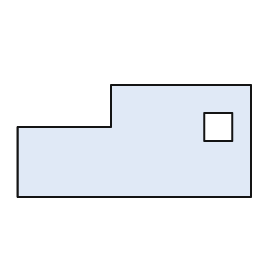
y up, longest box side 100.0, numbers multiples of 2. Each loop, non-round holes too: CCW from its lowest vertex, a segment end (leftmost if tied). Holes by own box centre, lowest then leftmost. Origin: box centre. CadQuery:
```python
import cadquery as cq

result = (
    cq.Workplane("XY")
    .moveTo(-50.0, -24.0)
    .lineTo(50.0, -24.0)
    .lineTo(50.0, 24.0)
    .lineTo(-10.0, 24.0)
    .lineTo(-10.0, 6.0)
    .lineTo(-50.0, 6.0)
    .close()
    .moveTo(30.0, 0.0)
    .lineTo(42.0, 0.0)
    .lineTo(42.0, 12.0)
    .lineTo(30.0, 12.0)
    .close()
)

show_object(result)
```